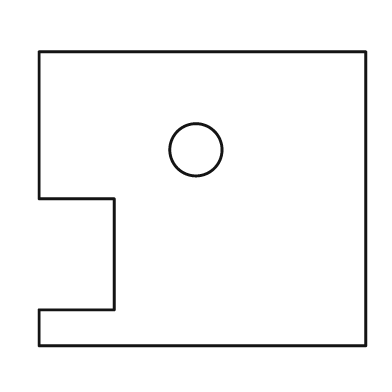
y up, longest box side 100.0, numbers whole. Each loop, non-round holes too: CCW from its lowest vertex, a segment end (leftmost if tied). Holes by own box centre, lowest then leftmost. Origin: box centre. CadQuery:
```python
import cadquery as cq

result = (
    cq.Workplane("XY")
    .moveTo(-50.0, -45.0)
    .lineTo(50.0, -45.0)
    .lineTo(50.0, 45.0)
    .lineTo(-50.0, 45.0)
    .lineTo(-50.0, 0.0)
    .lineTo(-27.0, 0.0)
    .lineTo(-27.0, -34.0)
    .lineTo(-50.0, -34.0)
    .close()
    .moveTo(-2.0, 15.0)
    .circle(8.0)
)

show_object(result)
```